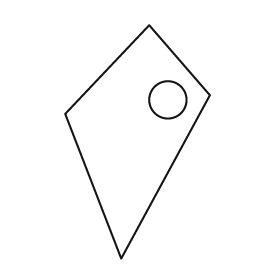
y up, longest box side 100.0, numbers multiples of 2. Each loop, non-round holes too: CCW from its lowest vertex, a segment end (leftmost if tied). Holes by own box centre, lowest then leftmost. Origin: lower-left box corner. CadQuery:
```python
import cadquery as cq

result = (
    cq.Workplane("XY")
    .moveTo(24.0, 0.0)
    .lineTo(62.0, 70.0)
    .lineTo(36.0, 100.0)
    .lineTo(0.0, 62.0)
    .close()
    .moveTo(44.0, 68.0)
    .circle(8.0)
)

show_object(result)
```